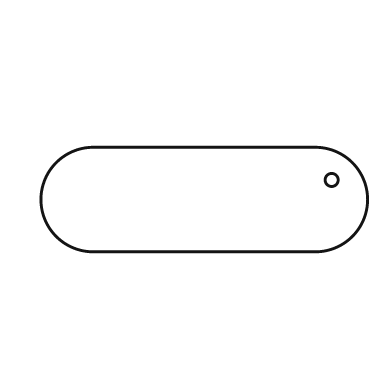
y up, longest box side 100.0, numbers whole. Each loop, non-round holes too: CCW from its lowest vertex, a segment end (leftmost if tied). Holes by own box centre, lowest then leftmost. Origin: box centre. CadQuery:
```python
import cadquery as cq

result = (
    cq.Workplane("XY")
    .moveTo(-34.0, -16.0)
    .lineTo(34.0, -16.0)
    .threePointArc((50.0, 0.0), (34.0, 16.0))
    .lineTo(-34.0, 16.0)
    .threePointArc((-50.0, 0.0), (-34.0, -16.0))
    .close()
    .moveTo(39.0, 6.0)
    .circle(2.0)
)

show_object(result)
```